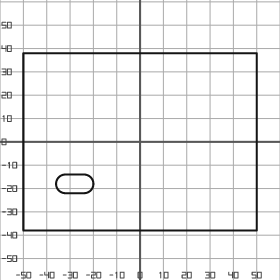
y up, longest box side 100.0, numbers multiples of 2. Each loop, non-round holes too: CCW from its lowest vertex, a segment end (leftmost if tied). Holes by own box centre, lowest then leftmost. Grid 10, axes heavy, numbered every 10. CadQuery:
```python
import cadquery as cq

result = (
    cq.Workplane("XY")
    .moveTo(-50.0, -38.0)
    .lineTo(50.0, -38.0)
    .lineTo(50.0, 38.0)
    .lineTo(-50.0, 38.0)
    .close()
    .moveTo(-32.0, -22.0)
    .lineTo(-24.0, -22.0)
    .threePointArc((-20.0, -18.0), (-24.0, -14.0))
    .lineTo(-32.0, -14.0)
    .threePointArc((-36.0, -18.0), (-32.0, -22.0))
    .close()
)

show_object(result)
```